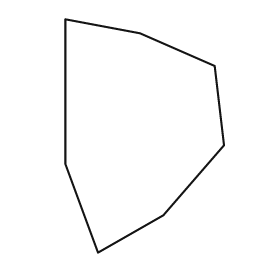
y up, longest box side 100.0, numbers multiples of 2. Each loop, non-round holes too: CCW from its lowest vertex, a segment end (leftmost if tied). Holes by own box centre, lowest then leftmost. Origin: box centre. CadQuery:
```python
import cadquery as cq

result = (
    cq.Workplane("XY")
    .moveTo(-20.0, -50.0)
    .lineTo(8.0, -34.0)
    .lineTo(34.0, -4.0)
    .lineTo(30.0, 30.0)
    .lineTo(-2.0, 44.0)
    .lineTo(-34.0, 50.0)
    .lineTo(-34.0, -12.0)
    .close()
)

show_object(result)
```